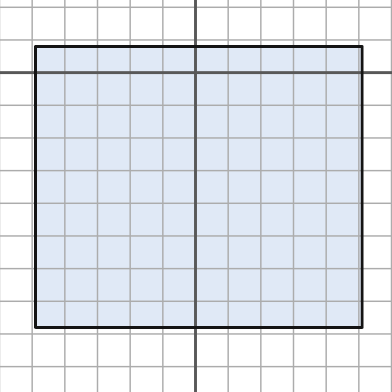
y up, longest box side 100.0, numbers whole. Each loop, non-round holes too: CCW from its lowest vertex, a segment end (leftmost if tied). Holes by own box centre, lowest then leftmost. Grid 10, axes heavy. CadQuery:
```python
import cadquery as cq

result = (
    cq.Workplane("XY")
    .moveTo(-49.0, -78.0)
    .lineTo(51.0, -78.0)
    .lineTo(51.0, 8.0)
    .lineTo(-49.0, 8.0)
    .close()
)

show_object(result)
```